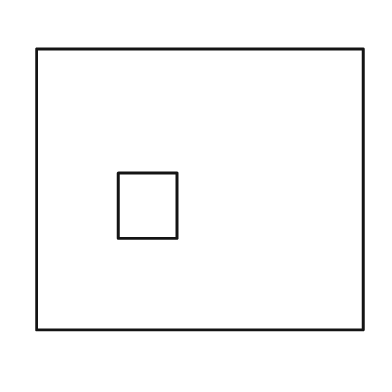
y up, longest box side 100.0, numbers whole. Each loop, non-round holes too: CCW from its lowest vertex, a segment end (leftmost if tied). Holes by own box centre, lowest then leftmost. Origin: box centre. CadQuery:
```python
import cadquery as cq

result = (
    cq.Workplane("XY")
    .moveTo(-50.0, -43.0)
    .lineTo(50.0, -43.0)
    .lineTo(50.0, 43.0)
    .lineTo(-50.0, 43.0)
    .close()
    .moveTo(-25.0, -15.0)
    .lineTo(-7.0, -15.0)
    .lineTo(-7.0, 5.0)
    .lineTo(-25.0, 5.0)
    .close()
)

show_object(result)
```